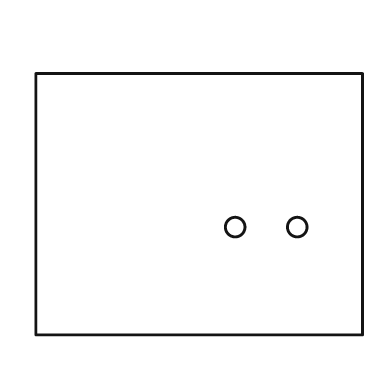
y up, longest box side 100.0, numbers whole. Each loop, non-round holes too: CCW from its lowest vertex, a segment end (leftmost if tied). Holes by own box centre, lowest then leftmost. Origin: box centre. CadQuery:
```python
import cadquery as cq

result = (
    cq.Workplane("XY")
    .moveTo(-50.0, -40.0)
    .lineTo(50.0, -40.0)
    .lineTo(50.0, 40.0)
    .lineTo(-50.0, 40.0)
    .close()
    .moveTo(11.0, -7.0)
    .circle(3.0)
    .moveTo(30.0, -7.0)
    .circle(3.0)
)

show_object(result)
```